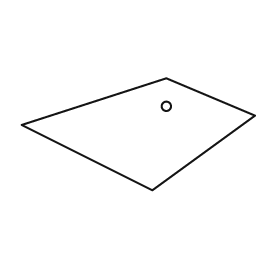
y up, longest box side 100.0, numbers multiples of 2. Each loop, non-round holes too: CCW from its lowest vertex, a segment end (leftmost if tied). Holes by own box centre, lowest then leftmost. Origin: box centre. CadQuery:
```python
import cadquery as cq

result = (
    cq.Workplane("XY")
    .moveTo(6.0, -24.0)
    .lineTo(50.0, 8.0)
    .lineTo(12.0, 24.0)
    .lineTo(-50.0, 4.0)
    .close()
    .moveTo(12.0, 12.0)
    .circle(2.0)
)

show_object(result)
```